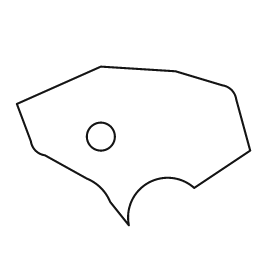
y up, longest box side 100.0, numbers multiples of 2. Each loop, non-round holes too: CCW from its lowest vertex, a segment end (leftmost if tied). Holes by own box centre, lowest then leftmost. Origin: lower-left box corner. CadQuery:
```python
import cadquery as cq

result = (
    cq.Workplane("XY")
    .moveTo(48.0, 0.0)
    .threePointArc((56.0, 18.0), (76.0, 16.0))
    .lineTo(100.0, 32.0)
    .lineTo(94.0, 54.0)
    .threePointArc((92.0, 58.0), (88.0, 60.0))
    .lineTo(68.0, 66.0)
    .lineTo(36.0, 68.0)
    .lineTo(0.0, 52.0)
    .lineTo(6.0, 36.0)
    .threePointArc((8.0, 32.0), (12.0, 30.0))
    .lineTo(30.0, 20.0)
    .threePointArc((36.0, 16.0), (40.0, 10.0))
    .close()
    .moveTo(36.0, 38.0)
    .circle(6.0)
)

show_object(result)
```